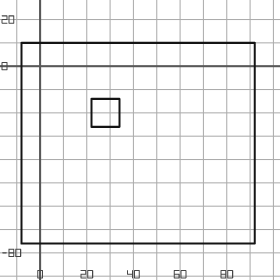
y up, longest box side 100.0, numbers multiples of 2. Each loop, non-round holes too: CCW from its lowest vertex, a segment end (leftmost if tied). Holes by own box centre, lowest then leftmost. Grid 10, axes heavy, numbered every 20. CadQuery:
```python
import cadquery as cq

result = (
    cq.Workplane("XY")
    .moveTo(-8.0, -76.0)
    .lineTo(92.0, -76.0)
    .lineTo(92.0, 10.0)
    .lineTo(-8.0, 10.0)
    .close()
    .moveTo(22.0, -26.0)
    .lineTo(34.0, -26.0)
    .lineTo(34.0, -14.0)
    .lineTo(22.0, -14.0)
    .close()
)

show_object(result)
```